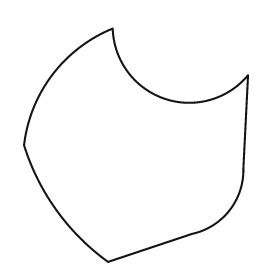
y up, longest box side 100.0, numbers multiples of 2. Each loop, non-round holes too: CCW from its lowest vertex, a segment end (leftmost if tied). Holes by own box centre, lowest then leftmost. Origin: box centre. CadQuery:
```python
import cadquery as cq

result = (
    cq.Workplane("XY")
    .moveTo(-12.0, -50.0)
    .lineTo(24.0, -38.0)
    .threePointArc((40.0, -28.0), (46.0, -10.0))
    .lineTo(48.0, 30.0)
    .threePointArc((12.0, 20.0), (-10.0, 50.0))
    .threePointArc((-36.0, 30.0), (-48.0, 0.0))
    .threePointArc((-34.0, -28.0), (-12.0, -50.0))
    .close()
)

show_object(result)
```